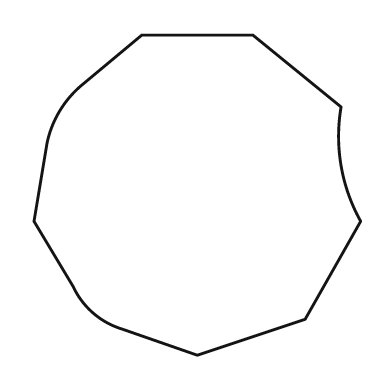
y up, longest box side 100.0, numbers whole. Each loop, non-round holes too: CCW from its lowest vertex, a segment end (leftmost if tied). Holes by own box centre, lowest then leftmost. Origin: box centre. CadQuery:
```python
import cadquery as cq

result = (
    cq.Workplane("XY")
    .moveTo(0.0, -49.0)
    .lineTo(33.0, -38.0)
    .lineTo(50.0, -8.0)
    .threePointArc((44.0, 9.0), (44.0, 27.0))
    .lineTo(17.0, 49.0)
    .lineTo(-17.0, 49.0)
    .lineTo(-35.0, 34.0)
    .threePointArc((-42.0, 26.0), (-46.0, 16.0))
    .lineTo(-50.0, -8.0)
    .lineTo(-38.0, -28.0)
    .threePointArc((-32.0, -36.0), (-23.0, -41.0))
    .close()
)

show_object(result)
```